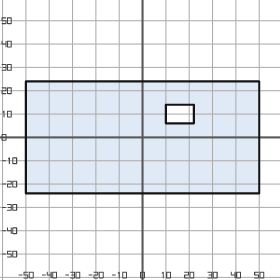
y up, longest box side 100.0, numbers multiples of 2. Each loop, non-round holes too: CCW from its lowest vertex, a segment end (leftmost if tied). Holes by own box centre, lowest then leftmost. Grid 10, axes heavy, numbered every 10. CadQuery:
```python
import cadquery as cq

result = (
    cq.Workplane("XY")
    .moveTo(-50.0, -24.0)
    .lineTo(50.0, -24.0)
    .lineTo(50.0, 24.0)
    .lineTo(-50.0, 24.0)
    .close()
    .moveTo(10.0, 6.0)
    .lineTo(22.0, 6.0)
    .lineTo(22.0, 14.0)
    .lineTo(10.0, 14.0)
    .close()
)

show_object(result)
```